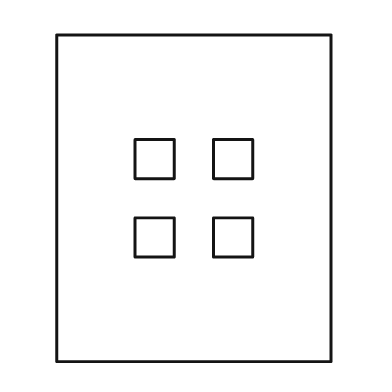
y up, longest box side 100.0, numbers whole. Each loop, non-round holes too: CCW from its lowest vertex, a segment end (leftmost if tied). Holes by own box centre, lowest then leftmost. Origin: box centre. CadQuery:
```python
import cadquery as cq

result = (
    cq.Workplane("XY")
    .moveTo(-42.0, -50.0)
    .lineTo(42.0, -50.0)
    .lineTo(42.0, 50.0)
    .lineTo(-42.0, 50.0)
    .close()
    .moveTo(-18.0, -18.0)
    .lineTo(-6.0, -18.0)
    .lineTo(-6.0, -6.0)
    .lineTo(-18.0, -6.0)
    .close()
    .moveTo(6.0, -18.0)
    .lineTo(18.0, -18.0)
    .lineTo(18.0, -6.0)
    .lineTo(6.0, -6.0)
    .close()
    .moveTo(-18.0, 6.0)
    .lineTo(-6.0, 6.0)
    .lineTo(-6.0, 18.0)
    .lineTo(-18.0, 18.0)
    .close()
    .moveTo(6.0, 6.0)
    .lineTo(18.0, 6.0)
    .lineTo(18.0, 18.0)
    .lineTo(6.0, 18.0)
    .close()
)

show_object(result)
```